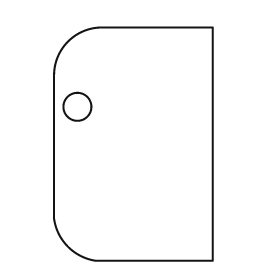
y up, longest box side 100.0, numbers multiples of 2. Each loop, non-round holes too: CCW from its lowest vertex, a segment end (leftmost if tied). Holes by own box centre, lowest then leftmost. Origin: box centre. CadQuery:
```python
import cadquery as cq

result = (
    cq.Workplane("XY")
    .moveTo(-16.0, -50.0)
    .lineTo(34.0, -50.0)
    .lineTo(34.0, 50.0)
    .lineTo(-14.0, 50.0)
    .threePointArc((-28.0, 44.0), (-34.0, 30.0))
    .lineTo(-34.0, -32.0)
    .threePointArc((-28.0, -44.0), (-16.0, -50.0))
    .close()
    .moveTo(-24.0, 16.0)
    .circle(6.0)
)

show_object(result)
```